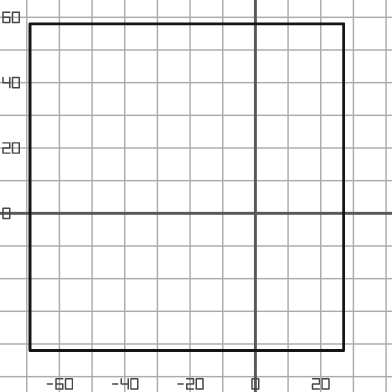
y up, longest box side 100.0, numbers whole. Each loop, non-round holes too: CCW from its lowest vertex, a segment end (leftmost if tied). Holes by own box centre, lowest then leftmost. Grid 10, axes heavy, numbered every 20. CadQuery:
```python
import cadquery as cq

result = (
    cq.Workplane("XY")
    .moveTo(-69.0, -42.0)
    .lineTo(27.0, -42.0)
    .lineTo(27.0, 58.0)
    .lineTo(-69.0, 58.0)
    .close()
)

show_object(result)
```